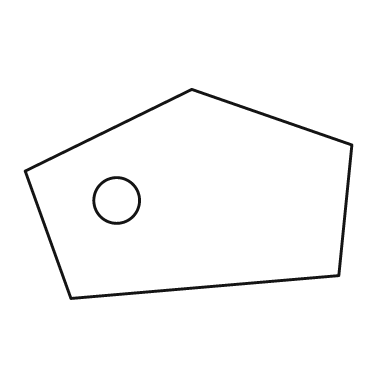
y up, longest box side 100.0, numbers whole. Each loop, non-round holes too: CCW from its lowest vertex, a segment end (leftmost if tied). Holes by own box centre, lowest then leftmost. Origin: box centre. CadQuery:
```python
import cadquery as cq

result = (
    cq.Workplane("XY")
    .moveTo(-36.0, -32.0)
    .lineTo(46.0, -25.0)
    .lineTo(50.0, 15.0)
    .lineTo(1.0, 32.0)
    .lineTo(-50.0, 7.0)
    .close()
    .moveTo(-22.0, -2.0)
    .circle(7.0)
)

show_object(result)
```